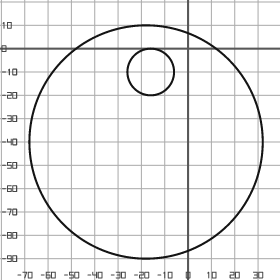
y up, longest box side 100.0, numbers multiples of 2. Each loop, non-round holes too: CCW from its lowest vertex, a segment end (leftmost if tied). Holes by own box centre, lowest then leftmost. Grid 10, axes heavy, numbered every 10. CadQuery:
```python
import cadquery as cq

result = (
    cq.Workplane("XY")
    .moveTo(-18.0, -40.0)
    .circle(50.0)
    .moveTo(-16.0, -10.0)
    .circle(10.0)
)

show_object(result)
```